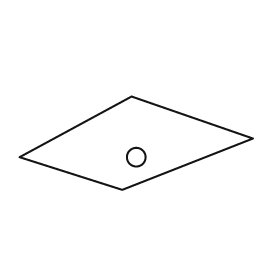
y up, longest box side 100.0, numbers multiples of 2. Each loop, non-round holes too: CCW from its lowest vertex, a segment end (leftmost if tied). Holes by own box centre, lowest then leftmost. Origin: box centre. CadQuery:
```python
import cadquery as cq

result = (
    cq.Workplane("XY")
    .moveTo(-6.0, -20.0)
    .lineTo(50.0, 2.0)
    .lineTo(-2.0, 20.0)
    .lineTo(-50.0, -6.0)
    .close()
    .moveTo(0.0, -6.0)
    .circle(4.0)
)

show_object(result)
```